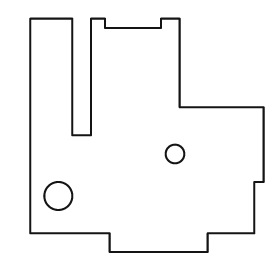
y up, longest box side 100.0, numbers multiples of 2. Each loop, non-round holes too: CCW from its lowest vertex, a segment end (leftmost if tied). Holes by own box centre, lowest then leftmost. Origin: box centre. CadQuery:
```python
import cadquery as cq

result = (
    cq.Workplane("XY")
    .moveTo(-16.0, -50.0)
    .lineTo(26.0, -50.0)
    .lineTo(26.0, -42.0)
    .lineTo(46.0, -42.0)
    .lineTo(46.0, -20.0)
    .lineTo(50.0, -20.0)
    .lineTo(50.0, 12.0)
    .lineTo(14.0, 12.0)
    .lineTo(14.0, 50.0)
    .lineTo(6.0, 50.0)
    .lineTo(6.0, 46.0)
    .lineTo(-18.0, 46.0)
    .lineTo(-18.0, 50.0)
    .lineTo(-24.0, 50.0)
    .lineTo(-24.0, 0.0)
    .lineTo(-32.0, 0.0)
    .lineTo(-32.0, 50.0)
    .lineTo(-50.0, 50.0)
    .lineTo(-50.0, -42.0)
    .lineTo(-16.0, -42.0)
    .close()
    .moveTo(-38.0, -26.0)
    .circle(6.0)
    .moveTo(12.0, -8.0)
    .circle(4.0)
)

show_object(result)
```